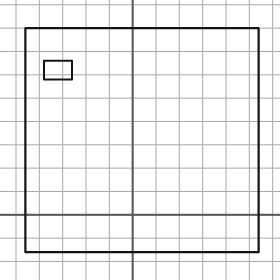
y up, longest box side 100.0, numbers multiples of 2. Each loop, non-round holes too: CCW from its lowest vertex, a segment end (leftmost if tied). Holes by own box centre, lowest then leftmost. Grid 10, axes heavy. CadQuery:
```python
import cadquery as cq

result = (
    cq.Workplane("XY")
    .moveTo(-46.0, -16.0)
    .lineTo(54.0, -16.0)
    .lineTo(54.0, 80.0)
    .lineTo(-46.0, 80.0)
    .close()
    .moveTo(-38.0, 58.0)
    .lineTo(-26.0, 58.0)
    .lineTo(-26.0, 66.0)
    .lineTo(-38.0, 66.0)
    .close()
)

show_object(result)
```